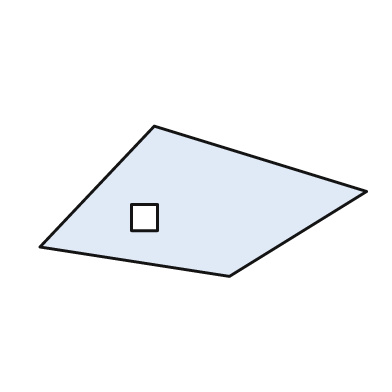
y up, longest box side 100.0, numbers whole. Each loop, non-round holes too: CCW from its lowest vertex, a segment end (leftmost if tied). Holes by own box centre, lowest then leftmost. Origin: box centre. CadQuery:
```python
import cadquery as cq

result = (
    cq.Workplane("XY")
    .moveTo(8.0, -23.0)
    .lineTo(50.0, 3.0)
    .lineTo(-15.0, 23.0)
    .lineTo(-50.0, -14.0)
    .close()
    .moveTo(-22.0, -9.0)
    .lineTo(-14.0, -9.0)
    .lineTo(-14.0, -1.0)
    .lineTo(-22.0, -1.0)
    .close()
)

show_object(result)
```